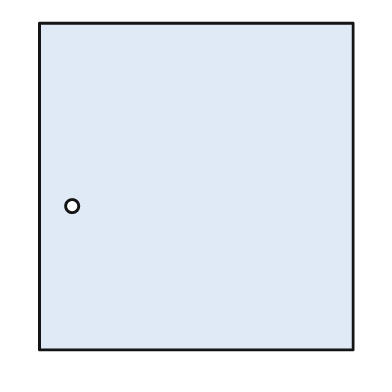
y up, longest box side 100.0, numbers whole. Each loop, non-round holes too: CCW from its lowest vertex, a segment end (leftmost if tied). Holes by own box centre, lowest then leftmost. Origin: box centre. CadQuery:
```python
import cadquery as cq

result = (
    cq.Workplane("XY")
    .moveTo(-48.0, -50.0)
    .lineTo(48.0, -50.0)
    .lineTo(48.0, 50.0)
    .lineTo(-48.0, 50.0)
    .close()
    .moveTo(-38.0, -6.0)
    .circle(2.0)
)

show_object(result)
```